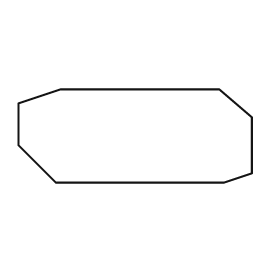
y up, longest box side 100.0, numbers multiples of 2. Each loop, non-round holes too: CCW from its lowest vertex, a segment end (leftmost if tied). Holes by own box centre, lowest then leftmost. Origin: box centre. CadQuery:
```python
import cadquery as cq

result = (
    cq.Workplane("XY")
    .moveTo(-34.0, -20.0)
    .lineTo(38.0, -20.0)
    .lineTo(50.0, -16.0)
    .lineTo(50.0, 8.0)
    .lineTo(36.0, 20.0)
    .lineTo(-32.0, 20.0)
    .lineTo(-50.0, 14.0)
    .lineTo(-50.0, -4.0)
    .close()
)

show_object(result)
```